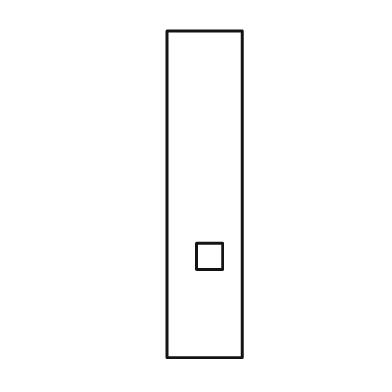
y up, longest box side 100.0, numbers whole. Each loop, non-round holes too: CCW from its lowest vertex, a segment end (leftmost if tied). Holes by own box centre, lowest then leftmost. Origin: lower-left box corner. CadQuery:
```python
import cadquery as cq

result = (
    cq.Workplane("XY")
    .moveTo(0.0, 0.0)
    .lineTo(23.0, 0.0)
    .lineTo(23.0, 100.0)
    .lineTo(0.0, 100.0)
    .close()
    .moveTo(9.0, 27.0)
    .lineTo(17.0, 27.0)
    .lineTo(17.0, 35.0)
    .lineTo(9.0, 35.0)
    .close()
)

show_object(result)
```